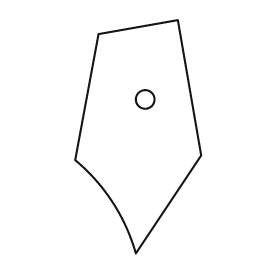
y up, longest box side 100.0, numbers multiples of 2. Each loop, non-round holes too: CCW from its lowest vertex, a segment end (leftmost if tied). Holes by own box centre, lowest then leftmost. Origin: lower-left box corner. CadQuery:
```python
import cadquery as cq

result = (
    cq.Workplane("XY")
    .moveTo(26.0, 0.0)
    .lineTo(54.0, 42.0)
    .lineTo(44.0, 100.0)
    .lineTo(10.0, 94.0)
    .lineTo(0.0, 40.0)
    .threePointArc((16.0, 22.0), (26.0, 0.0))
    .close()
    .moveTo(30.0, 66.0)
    .circle(4.0)
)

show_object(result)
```